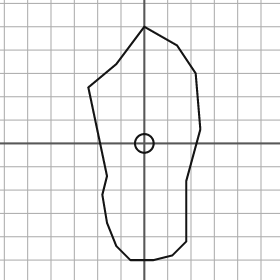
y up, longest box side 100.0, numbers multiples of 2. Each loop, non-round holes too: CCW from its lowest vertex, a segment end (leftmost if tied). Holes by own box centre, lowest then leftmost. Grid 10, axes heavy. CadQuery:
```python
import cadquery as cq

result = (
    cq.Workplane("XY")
    .moveTo(-6.0, -50.0)
    .lineTo(4.0, -50.0)
    .lineTo(12.0, -48.0)
    .lineTo(18.0, -42.0)
    .lineTo(18.0, -16.0)
    .lineTo(24.0, 6.0)
    .lineTo(22.0, 30.0)
    .lineTo(14.0, 42.0)
    .lineTo(0.0, 50.0)
    .lineTo(-12.0, 34.0)
    .lineTo(-24.0, 24.0)
    .lineTo(-16.0, -14.0)
    .lineTo(-18.0, -22.0)
    .lineTo(-16.0, -34.0)
    .lineTo(-12.0, -44.0)
    .close()
    .moveTo(0.0, 0.0)
    .circle(4.0)
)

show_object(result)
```